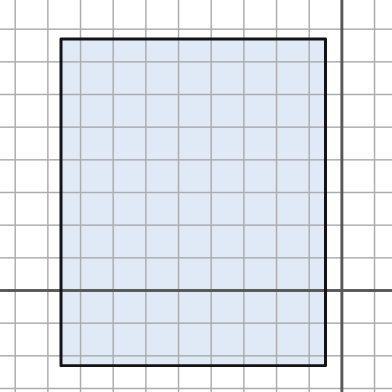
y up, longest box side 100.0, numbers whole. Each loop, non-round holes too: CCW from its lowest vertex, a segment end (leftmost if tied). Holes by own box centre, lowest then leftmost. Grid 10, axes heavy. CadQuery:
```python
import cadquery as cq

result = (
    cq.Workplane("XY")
    .moveTo(-86.0, -23.0)
    .lineTo(-5.0, -23.0)
    .lineTo(-5.0, 77.0)
    .lineTo(-86.0, 77.0)
    .close()
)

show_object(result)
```